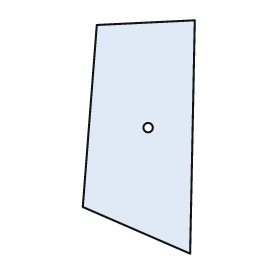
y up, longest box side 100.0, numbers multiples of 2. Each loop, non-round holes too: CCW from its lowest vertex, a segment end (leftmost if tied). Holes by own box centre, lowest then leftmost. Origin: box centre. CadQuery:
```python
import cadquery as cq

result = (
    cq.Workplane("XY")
    .moveTo(22.0, -50.0)
    .lineTo(24.0, 50.0)
    .lineTo(-18.0, 48.0)
    .lineTo(-24.0, -30.0)
    .close()
    .moveTo(4.0, 4.0)
    .circle(2.0)
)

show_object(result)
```